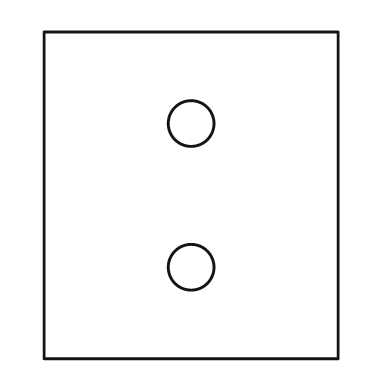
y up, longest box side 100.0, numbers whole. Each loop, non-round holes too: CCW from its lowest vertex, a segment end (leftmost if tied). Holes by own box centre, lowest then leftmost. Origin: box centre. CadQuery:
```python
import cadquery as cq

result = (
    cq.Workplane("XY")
    .moveTo(-45.0, -50.0)
    .lineTo(45.0, -50.0)
    .lineTo(45.0, 50.0)
    .lineTo(-45.0, 50.0)
    .close()
    .moveTo(0.0, -22.0)
    .circle(7.0)
    .moveTo(0.0, 22.0)
    .circle(7.0)
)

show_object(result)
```